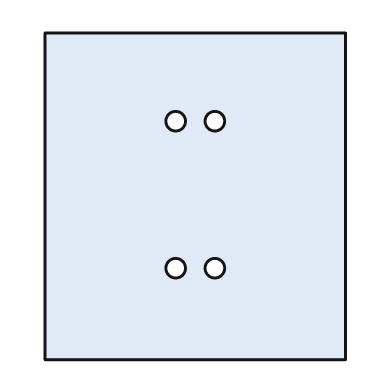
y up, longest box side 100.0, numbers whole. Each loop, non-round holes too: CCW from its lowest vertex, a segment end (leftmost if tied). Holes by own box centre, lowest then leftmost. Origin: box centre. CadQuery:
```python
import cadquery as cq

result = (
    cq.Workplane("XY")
    .moveTo(-46.0, -50.0)
    .lineTo(46.0, -50.0)
    .lineTo(46.0, 50.0)
    .lineTo(-46.0, 50.0)
    .close()
    .moveTo(-6.0, -22.0)
    .circle(3.0)
    .moveTo(6.0, -22.0)
    .circle(3.0)
    .moveTo(-6.0, 23.0)
    .circle(3.0)
    .moveTo(6.0, 23.0)
    .circle(3.0)
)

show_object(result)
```